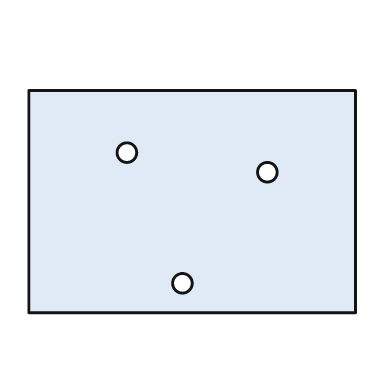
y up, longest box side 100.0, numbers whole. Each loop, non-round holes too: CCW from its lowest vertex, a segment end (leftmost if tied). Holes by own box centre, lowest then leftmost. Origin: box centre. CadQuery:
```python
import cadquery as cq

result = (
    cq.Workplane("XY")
    .moveTo(-50.0, -34.0)
    .lineTo(50.0, -34.0)
    .lineTo(50.0, 34.0)
    .lineTo(-50.0, 34.0)
    .close()
    .moveTo(-3.0, -25.0)
    .circle(3.0)
    .moveTo(23.0, 9.0)
    .circle(3.0)
    .moveTo(-20.0, 15.0)
    .circle(3.0)
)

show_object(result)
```